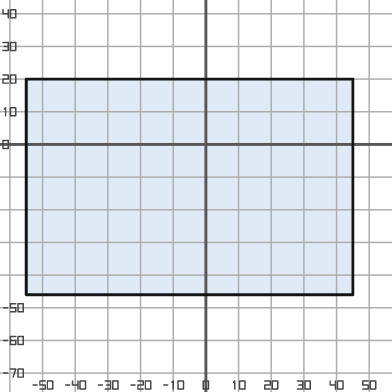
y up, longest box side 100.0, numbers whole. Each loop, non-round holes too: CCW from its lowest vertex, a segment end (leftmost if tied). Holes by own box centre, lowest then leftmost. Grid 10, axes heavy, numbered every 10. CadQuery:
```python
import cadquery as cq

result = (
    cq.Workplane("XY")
    .moveTo(-55.0, -46.0)
    .lineTo(45.0, -46.0)
    .lineTo(45.0, 20.0)
    .lineTo(-55.0, 20.0)
    .close()
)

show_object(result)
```